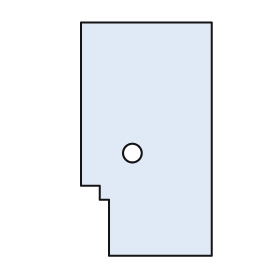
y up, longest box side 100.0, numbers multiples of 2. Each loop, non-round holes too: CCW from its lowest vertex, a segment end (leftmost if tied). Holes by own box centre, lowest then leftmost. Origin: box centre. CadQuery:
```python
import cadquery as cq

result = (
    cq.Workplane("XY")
    .moveTo(-16.0, -50.0)
    .lineTo(28.0, -50.0)
    .lineTo(28.0, 50.0)
    .lineTo(-28.0, 50.0)
    .lineTo(-28.0, -20.0)
    .lineTo(-20.0, -20.0)
    .lineTo(-20.0, -26.0)
    .lineTo(-16.0, -26.0)
    .close()
    .moveTo(-6.0, -6.0)
    .circle(4.0)
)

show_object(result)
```